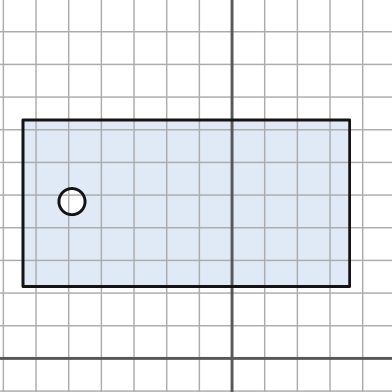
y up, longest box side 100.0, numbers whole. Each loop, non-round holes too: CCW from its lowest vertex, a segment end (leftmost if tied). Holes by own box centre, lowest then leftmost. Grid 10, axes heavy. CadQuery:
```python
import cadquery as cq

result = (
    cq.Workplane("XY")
    .moveTo(-64.0, 22.0)
    .lineTo(36.0, 22.0)
    .lineTo(36.0, 73.0)
    .lineTo(-64.0, 73.0)
    .close()
    .moveTo(-49.0, 48.0)
    .circle(4.0)
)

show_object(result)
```